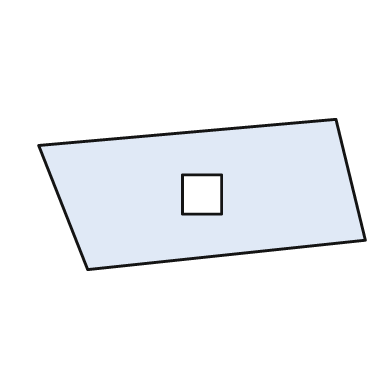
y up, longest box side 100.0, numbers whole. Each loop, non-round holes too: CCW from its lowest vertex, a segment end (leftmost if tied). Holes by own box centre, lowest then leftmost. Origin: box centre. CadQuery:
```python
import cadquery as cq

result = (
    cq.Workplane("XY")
    .moveTo(-35.0, -23.0)
    .lineTo(50.0, -14.0)
    .lineTo(41.0, 23.0)
    .lineTo(-50.0, 15.0)
    .close()
    .moveTo(-6.0, -6.0)
    .lineTo(6.0, -6.0)
    .lineTo(6.0, 6.0)
    .lineTo(-6.0, 6.0)
    .close()
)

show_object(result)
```